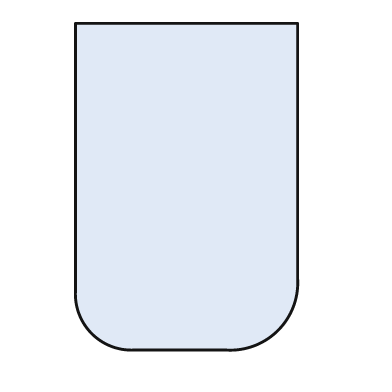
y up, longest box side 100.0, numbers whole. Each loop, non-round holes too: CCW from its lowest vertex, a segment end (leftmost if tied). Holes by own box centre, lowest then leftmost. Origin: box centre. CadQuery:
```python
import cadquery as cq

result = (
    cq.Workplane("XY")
    .moveTo(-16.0, -50.0)
    .lineTo(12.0, -50.0)
    .threePointArc((28.0, -44.0), (34.0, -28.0))
    .lineTo(34.0, 50.0)
    .lineTo(-34.0, 50.0)
    .lineTo(-34.0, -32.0)
    .threePointArc((-29.0, -45.0), (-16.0, -50.0))
    .close()
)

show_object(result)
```